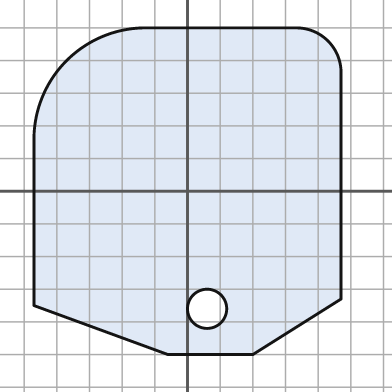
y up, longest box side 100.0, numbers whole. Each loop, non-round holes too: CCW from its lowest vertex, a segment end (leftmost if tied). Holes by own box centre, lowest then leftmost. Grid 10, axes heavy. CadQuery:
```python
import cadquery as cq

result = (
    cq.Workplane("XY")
    .moveTo(-6.0, -50.0)
    .lineTo(20.0, -50.0)
    .lineTo(47.0, -33.0)
    .lineTo(47.0, 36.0)
    .threePointArc((43.0, 46.0), (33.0, 50.0))
    .lineTo(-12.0, 50.0)
    .threePointArc((-37.0, 40.0), (-47.0, 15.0))
    .lineTo(-47.0, -35.0)
    .close()
    .moveTo(6.0, -36.0)
    .circle(6.0)
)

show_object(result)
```